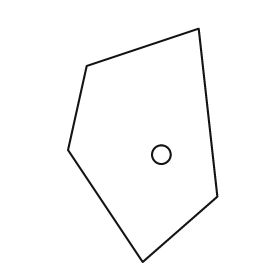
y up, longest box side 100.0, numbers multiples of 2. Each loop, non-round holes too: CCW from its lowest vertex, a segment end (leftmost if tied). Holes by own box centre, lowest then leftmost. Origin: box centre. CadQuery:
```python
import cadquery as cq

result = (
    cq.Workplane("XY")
    .moveTo(0.0, -50.0)
    .lineTo(32.0, -22.0)
    .lineTo(24.0, 50.0)
    .lineTo(-24.0, 34.0)
    .lineTo(-32.0, -2.0)
    .close()
    .moveTo(8.0, -4.0)
    .circle(4.0)
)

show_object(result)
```